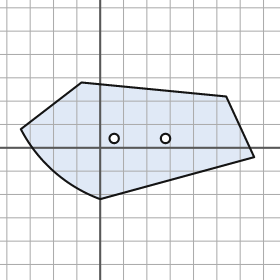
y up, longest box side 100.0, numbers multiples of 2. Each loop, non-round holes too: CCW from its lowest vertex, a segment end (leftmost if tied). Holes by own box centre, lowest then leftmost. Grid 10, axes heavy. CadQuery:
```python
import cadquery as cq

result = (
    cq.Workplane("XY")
    .moveTo(0.0, -22.0)
    .lineTo(66.0, -4.0)
    .lineTo(54.0, 22.0)
    .lineTo(-8.0, 28.0)
    .lineTo(-34.0, 8.0)
    .threePointArc((-20.0, -10.0), (0.0, -22.0))
    .close()
    .moveTo(6.0, 4.0)
    .circle(2.0)
    .moveTo(28.0, 4.0)
    .circle(2.0)
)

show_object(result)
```